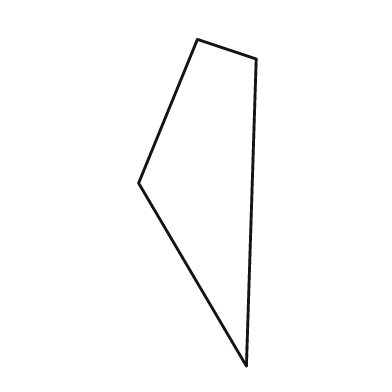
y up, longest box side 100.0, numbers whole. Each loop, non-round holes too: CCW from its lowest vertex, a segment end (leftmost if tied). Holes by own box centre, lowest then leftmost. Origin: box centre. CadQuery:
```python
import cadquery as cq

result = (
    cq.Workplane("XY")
    .moveTo(15.0, -50.0)
    .lineTo(18.0, 44.0)
    .lineTo(0.0, 50.0)
    .lineTo(-18.0, 6.0)
    .close()
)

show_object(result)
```